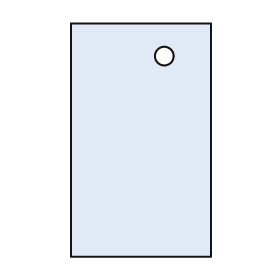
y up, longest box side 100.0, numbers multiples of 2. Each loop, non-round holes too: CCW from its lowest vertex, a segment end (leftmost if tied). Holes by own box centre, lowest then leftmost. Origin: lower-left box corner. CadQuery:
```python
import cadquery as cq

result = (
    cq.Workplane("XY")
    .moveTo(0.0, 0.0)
    .lineTo(60.0, 0.0)
    .lineTo(60.0, 100.0)
    .lineTo(0.0, 100.0)
    .close()
    .moveTo(40.0, 86.0)
    .circle(4.0)
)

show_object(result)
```